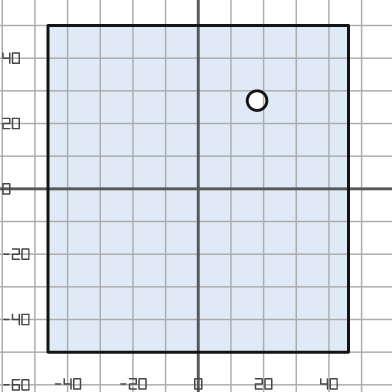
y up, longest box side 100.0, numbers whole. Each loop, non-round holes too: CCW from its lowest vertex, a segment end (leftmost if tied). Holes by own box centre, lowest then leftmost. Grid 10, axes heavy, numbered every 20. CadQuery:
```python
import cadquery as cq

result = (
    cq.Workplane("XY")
    .moveTo(-46.0, -50.0)
    .lineTo(46.0, -50.0)
    .lineTo(46.0, 50.0)
    .lineTo(-46.0, 50.0)
    .close()
    .moveTo(18.0, 27.0)
    .circle(3.0)
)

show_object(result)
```